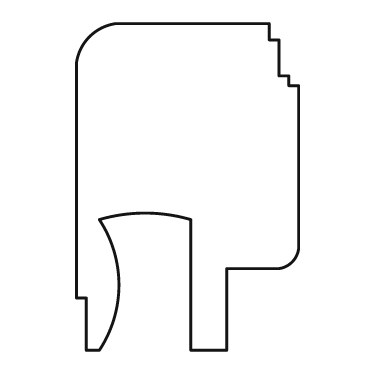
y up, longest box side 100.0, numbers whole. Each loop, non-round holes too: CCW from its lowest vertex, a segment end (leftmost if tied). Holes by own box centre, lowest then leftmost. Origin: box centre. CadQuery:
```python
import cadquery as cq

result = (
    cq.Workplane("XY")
    .moveTo(-31.0, -50.0)
    .lineTo(-27.0, -50.0)
    .threePointArc((-21.0, -30.0), (-27.0, -10.0))
    .threePointArc((-13.0, -8.0), (1.0, -10.0))
    .lineTo(1.0, -50.0)
    .lineTo(12.0, -50.0)
    .lineTo(12.0, -25.0)
    .lineTo(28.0, -25.0)
    .threePointArc((32.0, -23.0), (34.0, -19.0))
    .lineTo(34.0, 31.0)
    .lineTo(31.0, 31.0)
    .lineTo(31.0, 34.0)
    .lineTo(28.0, 34.0)
    .lineTo(28.0, 45.0)
    .lineTo(25.0, 45.0)
    .lineTo(25.0, 50.0)
    .lineTo(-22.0, 50.0)
    .threePointArc((-30.0, 46.0), (-34.0, 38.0))
    .lineTo(-34.0, -34.0)
    .lineTo(-31.0, -34.0)
    .close()
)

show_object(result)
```